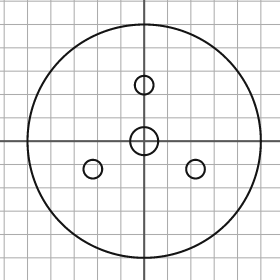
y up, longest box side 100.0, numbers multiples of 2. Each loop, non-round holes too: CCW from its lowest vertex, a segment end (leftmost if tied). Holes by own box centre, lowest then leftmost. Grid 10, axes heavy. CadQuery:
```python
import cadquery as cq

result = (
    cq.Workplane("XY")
    .moveTo(0.0, 0.0)
    .circle(50.0)
    .moveTo(-22.0, -12.0)
    .circle(4.0)
    .moveTo(22.0, -12.0)
    .circle(4.0)
    .moveTo(0.0, 0.0)
    .circle(6.0)
    .moveTo(0.0, 24.0)
    .circle(4.0)
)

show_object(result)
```